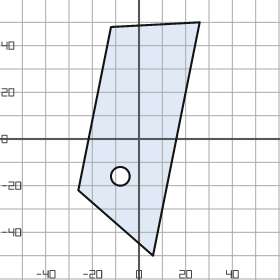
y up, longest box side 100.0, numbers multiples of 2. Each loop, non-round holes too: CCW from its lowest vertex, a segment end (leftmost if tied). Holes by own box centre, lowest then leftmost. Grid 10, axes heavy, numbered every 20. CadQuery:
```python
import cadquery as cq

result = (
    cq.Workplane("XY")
    .moveTo(6.0, -50.0)
    .lineTo(26.0, 50.0)
    .lineTo(-12.0, 48.0)
    .lineTo(-26.0, -22.0)
    .close()
    .moveTo(-8.0, -16.0)
    .circle(4.0)
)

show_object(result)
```